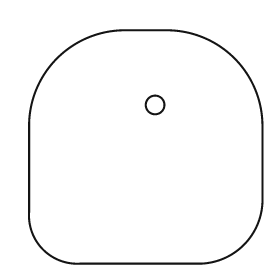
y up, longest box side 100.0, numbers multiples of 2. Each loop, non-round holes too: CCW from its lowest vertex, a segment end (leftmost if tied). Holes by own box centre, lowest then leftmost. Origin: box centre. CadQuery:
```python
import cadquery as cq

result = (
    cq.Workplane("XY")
    .moveTo(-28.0, -50.0)
    .lineTo(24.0, -50.0)
    .threePointArc((42.0, -42.0), (50.0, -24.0))
    .lineTo(50.0, 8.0)
    .threePointArc((38.0, 38.0), (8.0, 50.0))
    .lineTo(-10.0, 50.0)
    .threePointArc((-38.0, 38.0), (-50.0, 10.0))
    .lineTo(-50.0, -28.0)
    .threePointArc((-44.0, -44.0), (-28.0, -50.0))
    .close()
    .moveTo(4.0, 18.0)
    .circle(4.0)
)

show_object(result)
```